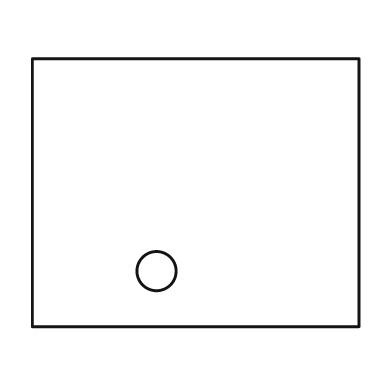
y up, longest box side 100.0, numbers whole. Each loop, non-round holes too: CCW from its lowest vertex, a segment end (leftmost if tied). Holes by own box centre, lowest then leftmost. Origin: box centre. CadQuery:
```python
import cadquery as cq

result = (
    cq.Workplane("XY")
    .moveTo(-50.0, -41.0)
    .lineTo(50.0, -41.0)
    .lineTo(50.0, 41.0)
    .lineTo(-50.0, 41.0)
    .close()
    .moveTo(-12.0, -24.0)
    .circle(6.0)
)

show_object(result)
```